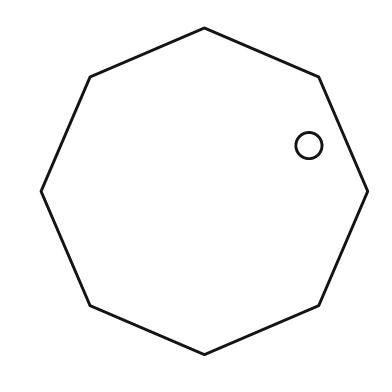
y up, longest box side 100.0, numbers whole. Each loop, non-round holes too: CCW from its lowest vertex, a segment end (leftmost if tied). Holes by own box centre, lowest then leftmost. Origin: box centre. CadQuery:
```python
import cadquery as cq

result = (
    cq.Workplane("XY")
    .moveTo(0.0, -50.0)
    .lineTo(35.0, -35.0)
    .lineTo(50.0, 0.0)
    .lineTo(35.0, 35.0)
    .lineTo(0.0, 50.0)
    .lineTo(-35.0, 35.0)
    .lineTo(-50.0, 0.0)
    .lineTo(-35.0, -35.0)
    .close()
    .moveTo(32.0, 14.0)
    .circle(4.0)
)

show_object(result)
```